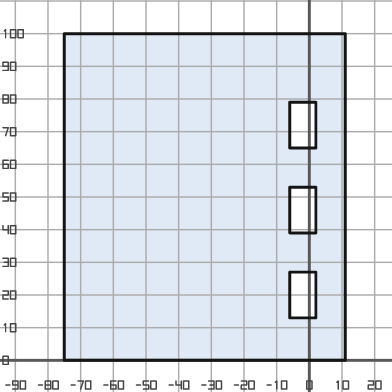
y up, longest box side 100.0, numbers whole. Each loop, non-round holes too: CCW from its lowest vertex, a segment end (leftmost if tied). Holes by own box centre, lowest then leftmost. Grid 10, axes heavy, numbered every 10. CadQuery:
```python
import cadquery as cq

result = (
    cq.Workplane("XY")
    .moveTo(-75.0, 0.0)
    .lineTo(11.0, 0.0)
    .lineTo(11.0, 100.0)
    .lineTo(-75.0, 100.0)
    .close()
    .moveTo(-6.0, 13.0)
    .lineTo(2.0, 13.0)
    .lineTo(2.0, 27.0)
    .lineTo(-6.0, 27.0)
    .close()
    .moveTo(-6.0, 39.0)
    .lineTo(2.0, 39.0)
    .lineTo(2.0, 53.0)
    .lineTo(-6.0, 53.0)
    .close()
    .moveTo(-6.0, 65.0)
    .lineTo(2.0, 65.0)
    .lineTo(2.0, 79.0)
    .lineTo(-6.0, 79.0)
    .close()
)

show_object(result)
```